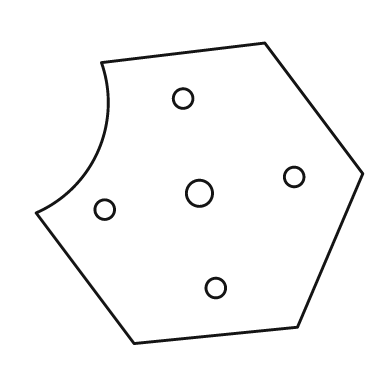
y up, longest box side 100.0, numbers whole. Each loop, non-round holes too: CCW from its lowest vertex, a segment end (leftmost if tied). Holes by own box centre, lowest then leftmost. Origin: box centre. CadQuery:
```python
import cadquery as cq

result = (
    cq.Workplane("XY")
    .moveTo(-20.0, -46.0)
    .lineTo(30.0, -41.0)
    .lineTo(50.0, 6.0)
    .lineTo(20.0, 46.0)
    .lineTo(-30.0, 40.0)
    .threePointArc((-31.0, 13.0), (-50.0, -6.0))
    .close()
    .moveTo(5.0, -29.0)
    .circle(3.0)
    .moveTo(-29.0, -5.0)
    .circle(3.0)
    .moveTo(0.0, 0.0)
    .circle(4.0)
    .moveTo(29.0, 5.0)
    .circle(3.0)
    .moveTo(-5.0, 29.0)
    .circle(3.0)
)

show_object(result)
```